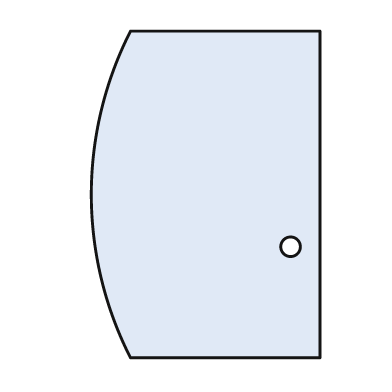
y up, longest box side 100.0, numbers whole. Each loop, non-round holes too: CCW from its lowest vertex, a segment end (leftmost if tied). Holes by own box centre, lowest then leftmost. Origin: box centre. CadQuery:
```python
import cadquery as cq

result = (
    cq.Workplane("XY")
    .moveTo(-23.0, -50.0)
    .lineTo(35.0, -50.0)
    .lineTo(35.0, 50.0)
    .lineTo(-23.0, 50.0)
    .threePointArc((-35.0, 0.0), (-23.0, -50.0))
    .close()
    .moveTo(26.0, -16.0)
    .circle(3.0)
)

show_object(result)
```